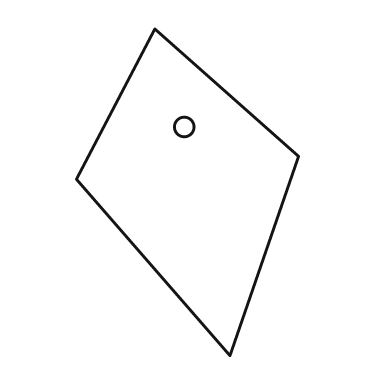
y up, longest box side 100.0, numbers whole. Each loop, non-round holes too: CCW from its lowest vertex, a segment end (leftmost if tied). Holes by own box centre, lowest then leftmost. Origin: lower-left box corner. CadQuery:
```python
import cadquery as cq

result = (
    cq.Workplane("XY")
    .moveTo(47.0, 0.0)
    .lineTo(68.0, 61.0)
    .lineTo(24.0, 100.0)
    .lineTo(0.0, 54.0)
    .close()
    .moveTo(33.0, 70.0)
    .circle(3.0)
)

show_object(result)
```